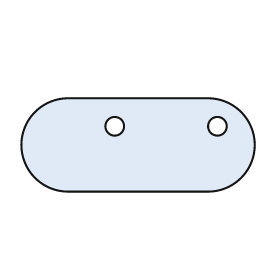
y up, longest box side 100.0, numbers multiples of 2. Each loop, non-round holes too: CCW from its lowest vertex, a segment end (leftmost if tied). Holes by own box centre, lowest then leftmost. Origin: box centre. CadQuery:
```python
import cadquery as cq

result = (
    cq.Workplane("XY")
    .moveTo(-30.0, -20.0)
    .lineTo(30.0, -20.0)
    .threePointArc((50.0, 0.0), (30.0, 20.0))
    .lineTo(-30.0, 20.0)
    .threePointArc((-50.0, 0.0), (-30.0, -20.0))
    .close()
    .moveTo(-10.0, 8.0)
    .circle(4.0)
    .moveTo(34.0, 8.0)
    .circle(4.0)
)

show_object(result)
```